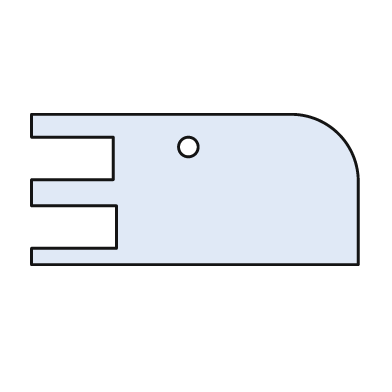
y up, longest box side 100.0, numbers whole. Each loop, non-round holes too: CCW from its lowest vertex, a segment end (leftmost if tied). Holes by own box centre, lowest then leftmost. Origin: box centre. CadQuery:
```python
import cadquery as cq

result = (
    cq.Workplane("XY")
    .moveTo(-50.0, -23.0)
    .lineTo(50.0, -23.0)
    .lineTo(50.0, 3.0)
    .threePointArc((44.0, 17.0), (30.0, 23.0))
    .lineTo(-50.0, 23.0)
    .lineTo(-50.0, 16.0)
    .lineTo(-25.0, 16.0)
    .lineTo(-25.0, 3.0)
    .lineTo(-50.0, 3.0)
    .lineTo(-50.0, -5.0)
    .lineTo(-24.0, -5.0)
    .lineTo(-24.0, -18.0)
    .lineTo(-50.0, -18.0)
    .close()
    .moveTo(-2.0, 13.0)
    .circle(3.0)
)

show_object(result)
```